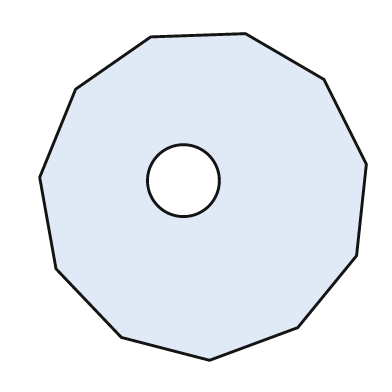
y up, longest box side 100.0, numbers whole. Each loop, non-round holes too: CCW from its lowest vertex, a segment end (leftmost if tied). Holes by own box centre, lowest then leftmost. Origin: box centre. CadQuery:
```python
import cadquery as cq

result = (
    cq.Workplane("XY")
    .moveTo(2.0, -50.0)
    .lineTo(29.0, -40.0)
    .lineTo(47.0, -18.0)
    .lineTo(50.0, 10.0)
    .lineTo(37.0, 36.0)
    .lineTo(13.0, 50.0)
    .lineTo(-16.0, 49.0)
    .lineTo(-39.0, 33.0)
    .lineTo(-50.0, 6.0)
    .lineTo(-45.0, -22.0)
    .lineTo(-25.0, -43.0)
    .close()
    .moveTo(-6.0, 5.0)
    .circle(11.0)
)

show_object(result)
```